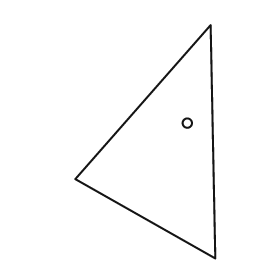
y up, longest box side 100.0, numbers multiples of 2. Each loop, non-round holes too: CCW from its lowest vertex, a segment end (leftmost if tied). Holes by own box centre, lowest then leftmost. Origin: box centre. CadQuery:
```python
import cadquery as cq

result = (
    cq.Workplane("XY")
    .moveTo(30.0, -50.0)
    .lineTo(28.0, 50.0)
    .lineTo(-30.0, -16.0)
    .close()
    .moveTo(18.0, 8.0)
    .circle(2.0)
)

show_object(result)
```